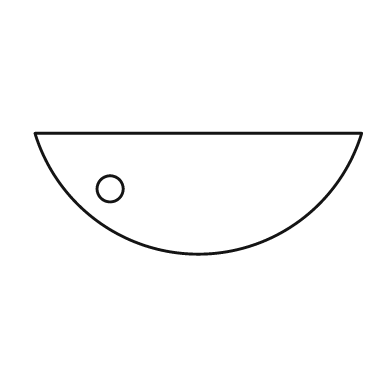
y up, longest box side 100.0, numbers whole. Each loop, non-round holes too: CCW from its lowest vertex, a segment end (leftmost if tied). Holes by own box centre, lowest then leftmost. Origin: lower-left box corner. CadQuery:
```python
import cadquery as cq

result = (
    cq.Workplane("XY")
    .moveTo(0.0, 37.0)
    .threePointArc((50.0, 0.0), (100.0, 37.0))
    .close()
    .moveTo(23.0, 20.0)
    .circle(4.0)
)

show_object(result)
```